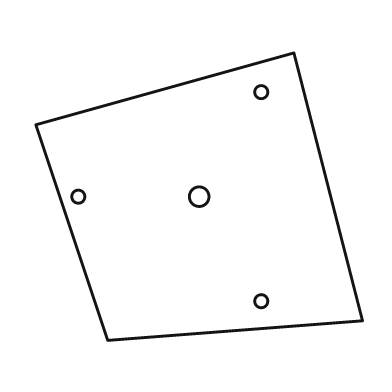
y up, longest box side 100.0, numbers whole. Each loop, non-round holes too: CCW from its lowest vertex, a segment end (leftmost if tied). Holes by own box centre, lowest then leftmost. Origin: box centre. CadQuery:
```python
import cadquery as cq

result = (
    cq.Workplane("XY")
    .moveTo(-28.0, -44.0)
    .lineTo(50.0, -38.0)
    .lineTo(29.0, 44.0)
    .lineTo(-50.0, 22.0)
    .close()
    .moveTo(19.0, -32.0)
    .circle(2.0)
    .moveTo(-37.0, 0.0)
    .circle(2.0)
    .moveTo(0.0, 0.0)
    .circle(3.0)
    .moveTo(19.0, 32.0)
    .circle(2.0)
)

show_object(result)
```